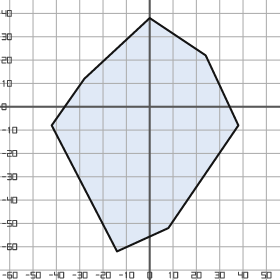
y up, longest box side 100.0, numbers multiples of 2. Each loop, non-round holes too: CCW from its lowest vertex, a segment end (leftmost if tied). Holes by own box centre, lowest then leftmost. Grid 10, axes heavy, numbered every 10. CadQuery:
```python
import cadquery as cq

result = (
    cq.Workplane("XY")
    .moveTo(-14.0, -62.0)
    .lineTo(8.0, -52.0)
    .lineTo(38.0, -8.0)
    .lineTo(24.0, 22.0)
    .lineTo(0.0, 38.0)
    .lineTo(-28.0, 12.0)
    .lineTo(-42.0, -8.0)
    .close()
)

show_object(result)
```